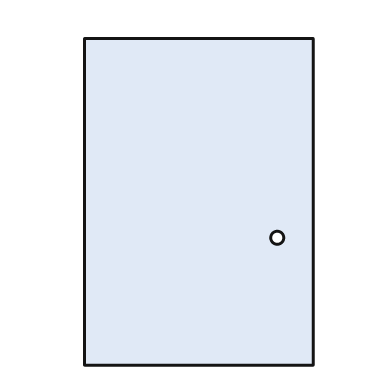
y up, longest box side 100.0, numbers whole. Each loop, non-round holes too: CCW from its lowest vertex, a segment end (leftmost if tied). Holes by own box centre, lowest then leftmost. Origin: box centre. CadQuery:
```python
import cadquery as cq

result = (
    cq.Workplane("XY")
    .moveTo(-35.0, -50.0)
    .lineTo(35.0, -50.0)
    .lineTo(35.0, 50.0)
    .lineTo(-35.0, 50.0)
    .close()
    .moveTo(24.0, -11.0)
    .circle(2.0)
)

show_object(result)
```